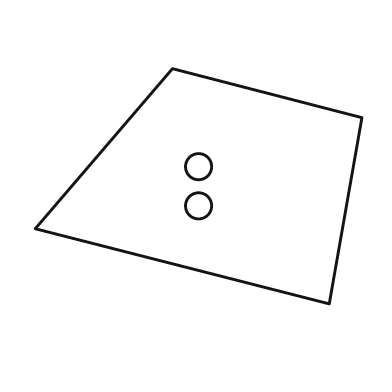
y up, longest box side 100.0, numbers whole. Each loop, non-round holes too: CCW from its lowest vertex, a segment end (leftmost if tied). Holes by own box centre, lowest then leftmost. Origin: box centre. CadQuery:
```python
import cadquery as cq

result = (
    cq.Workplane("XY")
    .moveTo(40.0, -36.0)
    .lineTo(50.0, 21.0)
    .lineTo(-8.0, 36.0)
    .lineTo(-50.0, -13.0)
    .close()
    .moveTo(0.0, -6.0)
    .circle(4.0)
    .moveTo(0.0, 6.0)
    .circle(4.0)
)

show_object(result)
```